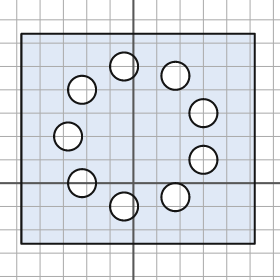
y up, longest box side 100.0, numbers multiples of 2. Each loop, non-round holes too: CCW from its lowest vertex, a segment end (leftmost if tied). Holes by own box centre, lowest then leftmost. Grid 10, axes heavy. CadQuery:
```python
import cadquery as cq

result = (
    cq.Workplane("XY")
    .moveTo(-48.0, -26.0)
    .lineTo(52.0, -26.0)
    .lineTo(52.0, 64.0)
    .lineTo(-48.0, 64.0)
    .close()
    .moveTo(-4.0, -10.0)
    .circle(6.0)
    .moveTo(18.0, -6.0)
    .circle(6.0)
    .moveTo(-22.0, 0.0)
    .circle(6.0)
    .moveTo(30.0, 10.0)
    .circle(6.0)
    .moveTo(-28.0, 20.0)
    .circle(6.0)
    .moveTo(30.0, 30.0)
    .circle(6.0)
    .moveTo(-22.0, 40.0)
    .circle(6.0)
    .moveTo(18.0, 46.0)
    .circle(6.0)
    .moveTo(-4.0, 50.0)
    .circle(6.0)
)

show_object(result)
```